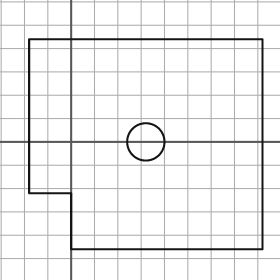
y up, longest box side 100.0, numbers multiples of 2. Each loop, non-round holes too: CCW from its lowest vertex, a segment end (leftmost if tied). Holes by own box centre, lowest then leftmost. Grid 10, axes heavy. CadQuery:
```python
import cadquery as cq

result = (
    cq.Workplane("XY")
    .moveTo(0.0, -46.0)
    .lineTo(82.0, -46.0)
    .lineTo(82.0, 44.0)
    .lineTo(-18.0, 44.0)
    .lineTo(-18.0, -22.0)
    .lineTo(0.0, -22.0)
    .close()
    .moveTo(32.0, 0.0)
    .circle(8.0)
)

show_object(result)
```